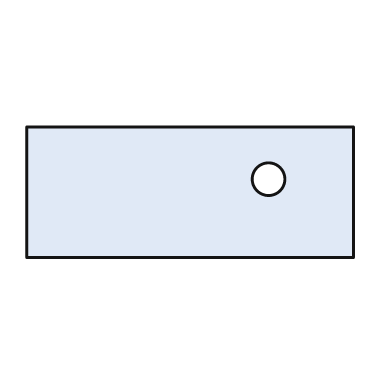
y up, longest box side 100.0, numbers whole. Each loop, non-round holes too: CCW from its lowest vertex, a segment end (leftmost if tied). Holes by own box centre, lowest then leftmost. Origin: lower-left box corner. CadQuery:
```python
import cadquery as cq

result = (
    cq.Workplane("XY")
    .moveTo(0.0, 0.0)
    .lineTo(100.0, 0.0)
    .lineTo(100.0, 40.0)
    .lineTo(0.0, 40.0)
    .close()
    .moveTo(74.0, 24.0)
    .circle(5.0)
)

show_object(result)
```